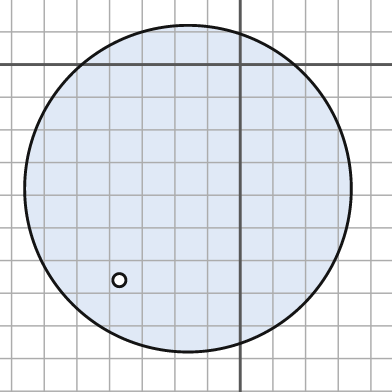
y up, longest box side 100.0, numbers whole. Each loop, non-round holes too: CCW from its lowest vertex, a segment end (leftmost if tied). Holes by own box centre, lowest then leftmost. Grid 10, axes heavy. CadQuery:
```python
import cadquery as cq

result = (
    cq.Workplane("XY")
    .moveTo(-16.0, -38.0)
    .circle(50.0)
    .moveTo(-37.0, -66.0)
    .circle(2.0)
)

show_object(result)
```